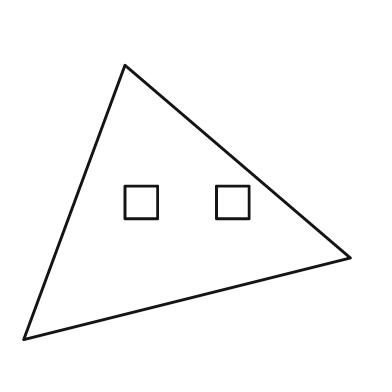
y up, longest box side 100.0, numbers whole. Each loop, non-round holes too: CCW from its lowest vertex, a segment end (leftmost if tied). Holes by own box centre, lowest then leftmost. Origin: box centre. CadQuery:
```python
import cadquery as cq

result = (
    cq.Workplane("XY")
    .moveTo(-50.0, -42.0)
    .lineTo(50.0, -17.0)
    .lineTo(-19.0, 42.0)
    .close()
    .moveTo(-19.0, -5.0)
    .lineTo(-9.0, -5.0)
    .lineTo(-9.0, 5.0)
    .lineTo(-19.0, 5.0)
    .close()
    .moveTo(9.0, -5.0)
    .lineTo(19.0, -5.0)
    .lineTo(19.0, 5.0)
    .lineTo(9.0, 5.0)
    .close()
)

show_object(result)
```